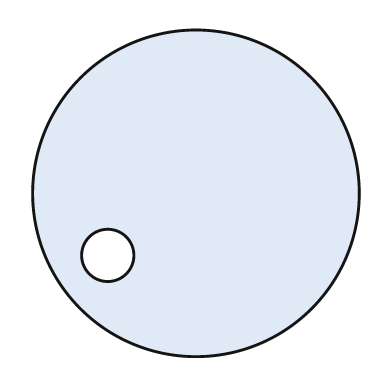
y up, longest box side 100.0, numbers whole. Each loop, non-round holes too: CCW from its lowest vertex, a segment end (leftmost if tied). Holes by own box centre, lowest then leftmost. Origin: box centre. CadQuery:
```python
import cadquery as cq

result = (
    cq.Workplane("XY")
    .moveTo(0.0, 0.0)
    .circle(50.0)
    .moveTo(-27.0, -19.0)
    .circle(8.0)
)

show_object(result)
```